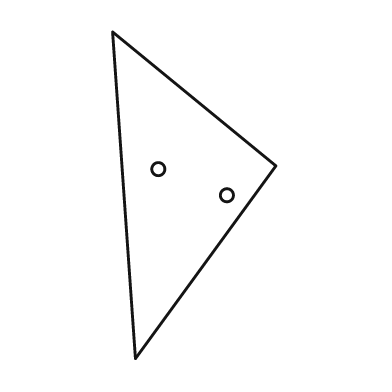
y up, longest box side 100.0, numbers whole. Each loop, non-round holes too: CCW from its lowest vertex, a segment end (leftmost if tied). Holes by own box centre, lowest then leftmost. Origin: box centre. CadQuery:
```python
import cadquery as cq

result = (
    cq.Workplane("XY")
    .moveTo(-18.0, -50.0)
    .lineTo(25.0, 9.0)
    .lineTo(-25.0, 50.0)
    .close()
    .moveTo(10.0, 0.0)
    .circle(2.0)
    .moveTo(-11.0, 8.0)
    .circle(2.0)
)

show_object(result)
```